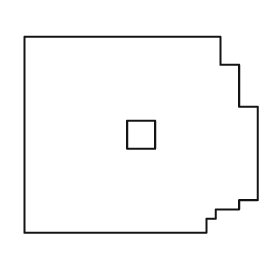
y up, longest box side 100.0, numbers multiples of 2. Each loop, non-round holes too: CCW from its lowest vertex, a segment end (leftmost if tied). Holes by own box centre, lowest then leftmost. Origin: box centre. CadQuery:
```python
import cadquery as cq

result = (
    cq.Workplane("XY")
    .moveTo(-50.0, -42.0)
    .lineTo(28.0, -42.0)
    .lineTo(28.0, -36.0)
    .lineTo(32.0, -36.0)
    .lineTo(32.0, -32.0)
    .lineTo(42.0, -32.0)
    .lineTo(42.0, -28.0)
    .lineTo(50.0, -28.0)
    .lineTo(50.0, 12.0)
    .lineTo(42.0, 12.0)
    .lineTo(42.0, 30.0)
    .lineTo(34.0, 30.0)
    .lineTo(34.0, 42.0)
    .lineTo(-50.0, 42.0)
    .close()
    .moveTo(-6.0, -6.0)
    .lineTo(6.0, -6.0)
    .lineTo(6.0, 6.0)
    .lineTo(-6.0, 6.0)
    .close()
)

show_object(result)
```